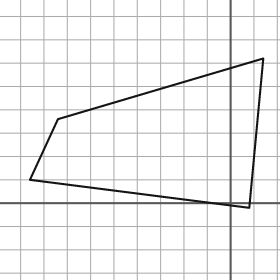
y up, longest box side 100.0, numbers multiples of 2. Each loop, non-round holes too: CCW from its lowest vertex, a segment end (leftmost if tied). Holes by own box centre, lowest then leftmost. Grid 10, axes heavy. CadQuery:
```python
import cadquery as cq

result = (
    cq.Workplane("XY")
    .moveTo(8.0, -2.0)
    .lineTo(14.0, 62.0)
    .lineTo(-74.0, 36.0)
    .lineTo(-86.0, 10.0)
    .close()
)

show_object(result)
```